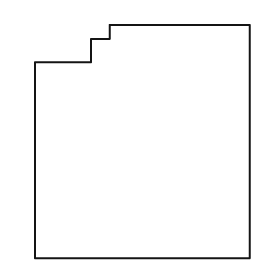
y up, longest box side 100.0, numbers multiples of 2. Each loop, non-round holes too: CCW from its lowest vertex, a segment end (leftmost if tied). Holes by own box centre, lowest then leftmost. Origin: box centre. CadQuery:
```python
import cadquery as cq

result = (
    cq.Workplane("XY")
    .moveTo(-46.0, -50.0)
    .lineTo(46.0, -50.0)
    .lineTo(46.0, 50.0)
    .lineTo(-14.0, 50.0)
    .lineTo(-14.0, 44.0)
    .lineTo(-22.0, 44.0)
    .lineTo(-22.0, 34.0)
    .lineTo(-46.0, 34.0)
    .close()
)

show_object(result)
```